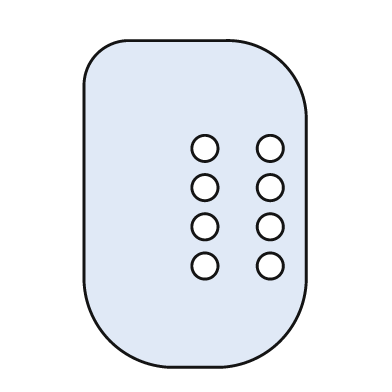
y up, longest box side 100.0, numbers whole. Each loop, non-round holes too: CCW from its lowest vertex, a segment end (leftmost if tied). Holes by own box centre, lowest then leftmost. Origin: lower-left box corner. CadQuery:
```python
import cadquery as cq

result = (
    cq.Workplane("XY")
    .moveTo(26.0, 0.0)
    .lineTo(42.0, 0.0)
    .threePointArc((60.0, 8.0), (68.0, 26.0))
    .lineTo(68.0, 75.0)
    .threePointArc((61.0, 93.0), (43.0, 100.0))
    .lineTo(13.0, 100.0)
    .threePointArc((4.0, 96.0), (0.0, 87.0))
    .lineTo(0.0, 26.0)
    .threePointArc((8.0, 8.0), (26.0, 0.0))
    .close()
    .moveTo(37.0, 31.0)
    .circle(4.0)
    .moveTo(57.0, 31.0)
    .circle(4.0)
    .moveTo(37.0, 43.0)
    .circle(4.0)
    .moveTo(57.0, 43.0)
    .circle(4.0)
    .moveTo(37.0, 55.0)
    .circle(4.0)
    .moveTo(57.0, 55.0)
    .circle(4.0)
    .moveTo(37.0, 67.0)
    .circle(4.0)
    .moveTo(57.0, 67.0)
    .circle(4.0)
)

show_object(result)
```